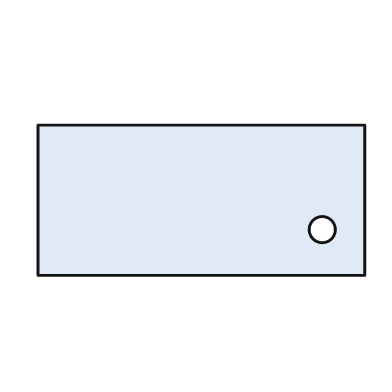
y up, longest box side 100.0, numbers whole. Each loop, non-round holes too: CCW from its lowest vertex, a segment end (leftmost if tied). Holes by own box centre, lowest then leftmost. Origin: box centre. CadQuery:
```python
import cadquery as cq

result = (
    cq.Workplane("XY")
    .moveTo(-50.0, -23.0)
    .lineTo(50.0, -23.0)
    .lineTo(50.0, 23.0)
    .lineTo(-50.0, 23.0)
    .close()
    .moveTo(37.0, -9.0)
    .circle(4.0)
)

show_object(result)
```